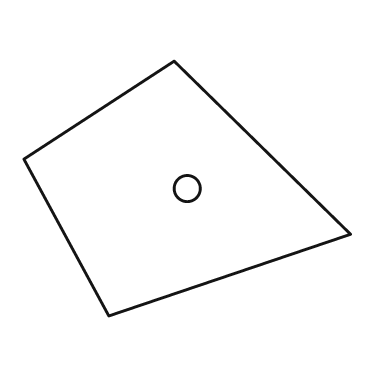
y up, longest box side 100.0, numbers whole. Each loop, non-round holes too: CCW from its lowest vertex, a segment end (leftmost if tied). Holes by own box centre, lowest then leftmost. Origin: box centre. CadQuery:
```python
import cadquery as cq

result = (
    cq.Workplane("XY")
    .moveTo(-24.0, -39.0)
    .lineTo(50.0, -14.0)
    .lineTo(-4.0, 39.0)
    .lineTo(-50.0, 9.0)
    .close()
    .moveTo(0.0, 0.0)
    .circle(4.0)
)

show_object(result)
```